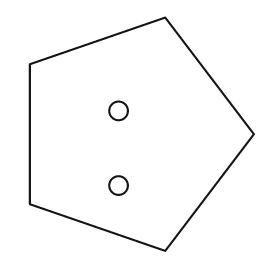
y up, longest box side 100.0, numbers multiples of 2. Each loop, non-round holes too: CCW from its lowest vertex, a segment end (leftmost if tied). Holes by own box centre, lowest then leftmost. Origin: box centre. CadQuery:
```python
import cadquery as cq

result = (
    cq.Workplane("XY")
    .moveTo(10.0, -50.0)
    .lineTo(48.0, 0.0)
    .lineTo(10.0, 50.0)
    .lineTo(-48.0, 30.0)
    .lineTo(-48.0, -30.0)
    .close()
    .moveTo(-10.0, -22.0)
    .circle(4.0)
    .moveTo(-10.0, 10.0)
    .circle(4.0)
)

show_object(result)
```